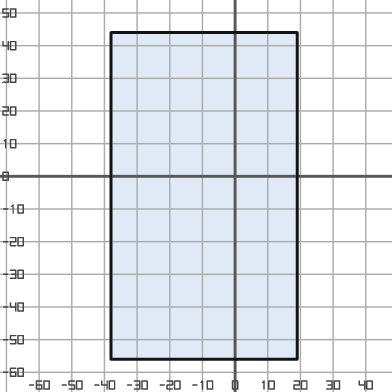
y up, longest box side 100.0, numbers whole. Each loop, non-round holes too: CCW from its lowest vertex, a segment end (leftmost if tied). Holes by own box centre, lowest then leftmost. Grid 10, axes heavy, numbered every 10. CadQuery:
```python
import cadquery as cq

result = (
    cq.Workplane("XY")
    .moveTo(-38.0, -56.0)
    .lineTo(19.0, -56.0)
    .lineTo(19.0, 44.0)
    .lineTo(-38.0, 44.0)
    .close()
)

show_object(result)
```